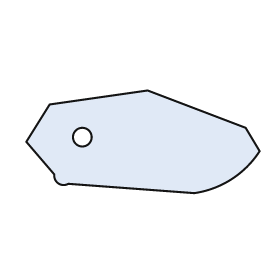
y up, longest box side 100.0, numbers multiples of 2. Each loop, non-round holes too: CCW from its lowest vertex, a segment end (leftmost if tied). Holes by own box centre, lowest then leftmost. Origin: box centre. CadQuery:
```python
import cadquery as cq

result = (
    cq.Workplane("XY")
    .moveTo(22.0, -22.0)
    .threePointArc((38.0, -16.0), (50.0, -4.0))
    .lineTo(44.0, 6.0)
    .lineTo(2.0, 22.0)
    .lineTo(-40.0, 16.0)
    .lineTo(-50.0, 0.0)
    .lineTo(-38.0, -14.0)
    .threePointArc((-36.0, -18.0), (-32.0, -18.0))
    .close()
    .moveTo(-26.0, 2.0)
    .circle(4.0)
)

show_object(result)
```